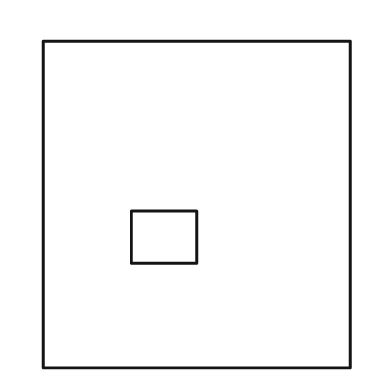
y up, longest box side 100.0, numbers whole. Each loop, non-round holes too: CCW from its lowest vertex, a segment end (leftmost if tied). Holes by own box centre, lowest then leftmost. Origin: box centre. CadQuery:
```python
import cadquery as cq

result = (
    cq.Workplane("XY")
    .moveTo(-47.0, -50.0)
    .lineTo(47.0, -50.0)
    .lineTo(47.0, 50.0)
    .lineTo(-47.0, 50.0)
    .close()
    .moveTo(-20.0, -18.0)
    .lineTo(0.0, -18.0)
    .lineTo(0.0, -2.0)
    .lineTo(-20.0, -2.0)
    .close()
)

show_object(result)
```